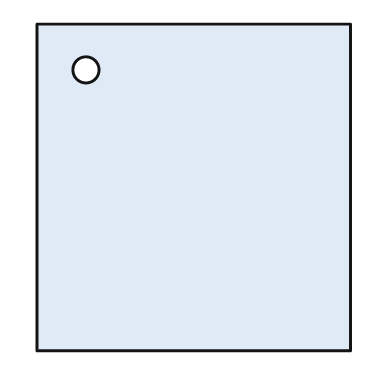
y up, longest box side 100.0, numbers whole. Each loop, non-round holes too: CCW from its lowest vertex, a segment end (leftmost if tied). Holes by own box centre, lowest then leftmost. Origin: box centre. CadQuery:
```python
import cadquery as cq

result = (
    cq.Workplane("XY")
    .moveTo(-48.0, -50.0)
    .lineTo(48.0, -50.0)
    .lineTo(48.0, 50.0)
    .lineTo(-48.0, 50.0)
    .close()
    .moveTo(-33.0, 36.0)
    .circle(4.0)
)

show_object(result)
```